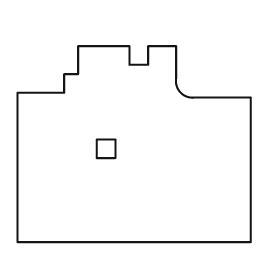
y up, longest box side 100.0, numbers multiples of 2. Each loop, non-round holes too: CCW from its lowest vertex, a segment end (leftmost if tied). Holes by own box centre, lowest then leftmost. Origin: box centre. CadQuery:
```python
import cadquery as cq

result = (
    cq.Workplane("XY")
    .moveTo(-50.0, -42.0)
    .lineTo(50.0, -42.0)
    .lineTo(50.0, 20.0)
    .lineTo(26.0, 20.0)
    .threePointArc((20.0, 22.0), (18.0, 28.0))
    .lineTo(18.0, 42.0)
    .lineTo(6.0, 42.0)
    .lineTo(6.0, 34.0)
    .lineTo(-2.0, 34.0)
    .lineTo(-2.0, 42.0)
    .lineTo(-24.0, 42.0)
    .lineTo(-24.0, 30.0)
    .lineTo(-30.0, 30.0)
    .lineTo(-30.0, 22.0)
    .lineTo(-50.0, 22.0)
    .close()
    .moveTo(-16.0, -6.0)
    .lineTo(-8.0, -6.0)
    .lineTo(-8.0, 2.0)
    .lineTo(-16.0, 2.0)
    .close()
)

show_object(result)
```